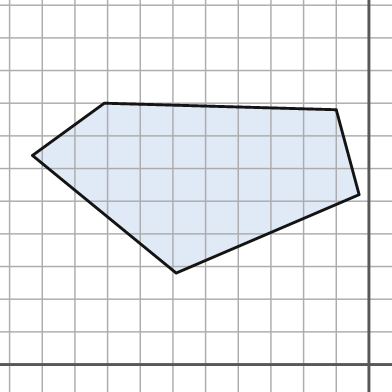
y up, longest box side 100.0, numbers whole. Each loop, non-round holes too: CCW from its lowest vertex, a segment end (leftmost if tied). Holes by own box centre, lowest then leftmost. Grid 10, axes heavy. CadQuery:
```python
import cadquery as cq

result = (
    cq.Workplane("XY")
    .moveTo(-59.0, 28.0)
    .lineTo(-3.0, 52.0)
    .lineTo(-10.0, 78.0)
    .lineTo(-81.0, 80.0)
    .lineTo(-103.0, 64.0)
    .close()
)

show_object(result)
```